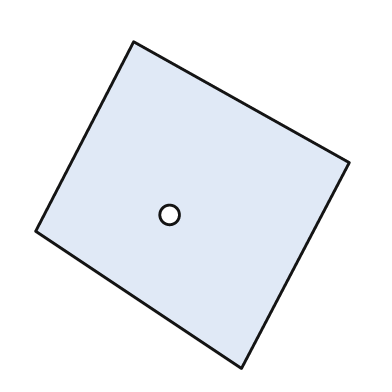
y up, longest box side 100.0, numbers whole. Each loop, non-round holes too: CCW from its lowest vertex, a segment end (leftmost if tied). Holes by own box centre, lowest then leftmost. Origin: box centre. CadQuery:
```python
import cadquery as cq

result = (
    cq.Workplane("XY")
    .moveTo(15.0, -50.0)
    .lineTo(48.0, 13.0)
    .lineTo(-18.0, 50.0)
    .lineTo(-48.0, -8.0)
    .close()
    .moveTo(-7.0, -3.0)
    .circle(3.0)
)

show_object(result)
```